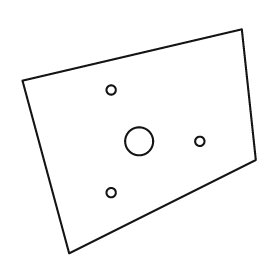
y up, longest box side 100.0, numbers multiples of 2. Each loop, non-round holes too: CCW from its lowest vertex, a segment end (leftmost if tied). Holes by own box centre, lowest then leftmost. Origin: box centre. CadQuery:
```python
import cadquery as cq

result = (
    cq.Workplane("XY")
    .moveTo(-30.0, -48.0)
    .lineTo(50.0, -8.0)
    .lineTo(44.0, 48.0)
    .lineTo(-50.0, 26.0)
    .close()
    .moveTo(-12.0, -22.0)
    .circle(2.0)
    .moveTo(0.0, 0.0)
    .circle(6.0)
    .moveTo(26.0, 0.0)
    .circle(2.0)
    .moveTo(-12.0, 22.0)
    .circle(2.0)
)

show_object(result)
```